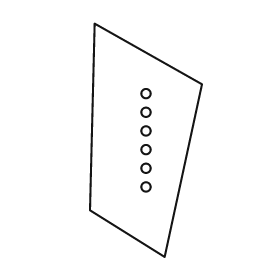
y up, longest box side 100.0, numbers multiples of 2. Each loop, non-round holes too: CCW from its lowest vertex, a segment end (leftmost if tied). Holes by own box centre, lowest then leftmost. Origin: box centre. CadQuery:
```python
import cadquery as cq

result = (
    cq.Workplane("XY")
    .moveTo(8.0, -50.0)
    .lineTo(24.0, 24.0)
    .lineTo(-22.0, 50.0)
    .lineTo(-24.0, -30.0)
    .close()
    .moveTo(0.0, -20.0)
    .circle(2.0)
    .moveTo(0.0, -12.0)
    .circle(2.0)
    .moveTo(0.0, -4.0)
    .circle(2.0)
    .moveTo(0.0, 4.0)
    .circle(2.0)
    .moveTo(0.0, 12.0)
    .circle(2.0)
    .moveTo(0.0, 20.0)
    .circle(2.0)
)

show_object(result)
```